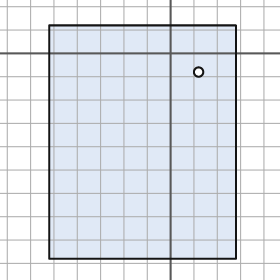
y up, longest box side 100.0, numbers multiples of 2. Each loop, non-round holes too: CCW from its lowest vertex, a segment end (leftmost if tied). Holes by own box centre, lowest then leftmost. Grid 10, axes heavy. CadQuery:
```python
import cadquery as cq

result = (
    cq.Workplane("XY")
    .moveTo(-52.0, -88.0)
    .lineTo(28.0, -88.0)
    .lineTo(28.0, 12.0)
    .lineTo(-52.0, 12.0)
    .close()
    .moveTo(12.0, -8.0)
    .circle(2.0)
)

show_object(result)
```